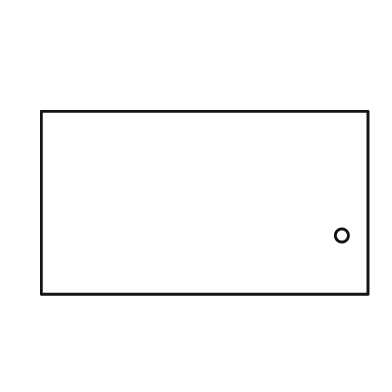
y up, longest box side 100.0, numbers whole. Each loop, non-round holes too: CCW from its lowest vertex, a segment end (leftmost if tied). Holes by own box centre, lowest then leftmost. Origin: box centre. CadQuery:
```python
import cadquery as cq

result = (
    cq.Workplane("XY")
    .moveTo(-50.0, -28.0)
    .lineTo(50.0, -28.0)
    .lineTo(50.0, 28.0)
    .lineTo(-50.0, 28.0)
    .close()
    .moveTo(42.0, -10.0)
    .circle(2.0)
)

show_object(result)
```